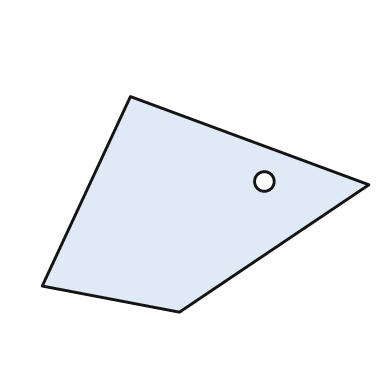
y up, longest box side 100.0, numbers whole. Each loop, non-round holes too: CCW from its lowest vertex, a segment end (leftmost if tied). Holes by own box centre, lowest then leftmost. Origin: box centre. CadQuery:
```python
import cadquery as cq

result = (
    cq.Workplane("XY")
    .moveTo(-8.0, -33.0)
    .lineTo(50.0, 6.0)
    .lineTo(-23.0, 33.0)
    .lineTo(-50.0, -25.0)
    .close()
    .moveTo(18.0, 7.0)
    .circle(3.0)
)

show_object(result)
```